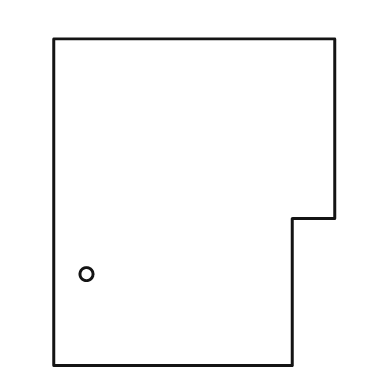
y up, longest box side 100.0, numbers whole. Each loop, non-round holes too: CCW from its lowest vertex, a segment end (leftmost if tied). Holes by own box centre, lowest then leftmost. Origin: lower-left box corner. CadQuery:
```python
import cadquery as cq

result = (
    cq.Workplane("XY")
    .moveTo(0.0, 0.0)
    .lineTo(73.0, 0.0)
    .lineTo(73.0, 45.0)
    .lineTo(86.0, 45.0)
    .lineTo(86.0, 100.0)
    .lineTo(0.0, 100.0)
    .close()
    .moveTo(10.0, 28.0)
    .circle(2.0)
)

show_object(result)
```